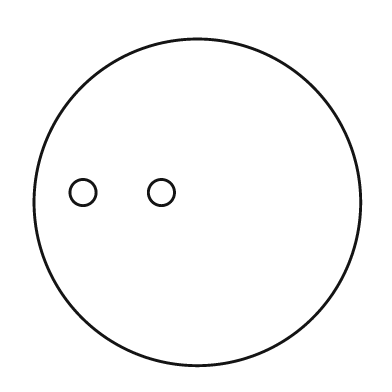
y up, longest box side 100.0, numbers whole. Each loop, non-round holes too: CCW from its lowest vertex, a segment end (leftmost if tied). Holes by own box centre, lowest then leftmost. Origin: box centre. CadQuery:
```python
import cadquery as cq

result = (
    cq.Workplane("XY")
    .moveTo(0.0, 0.0)
    .circle(50.0)
    .moveTo(-35.0, 3.0)
    .circle(4.0)
    .moveTo(-11.0, 3.0)
    .circle(4.0)
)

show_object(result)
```